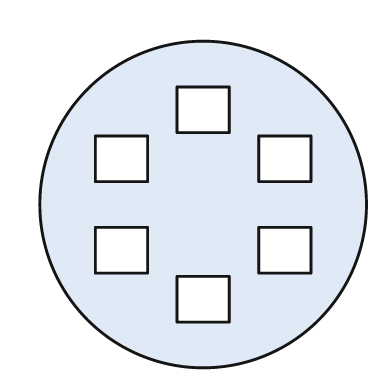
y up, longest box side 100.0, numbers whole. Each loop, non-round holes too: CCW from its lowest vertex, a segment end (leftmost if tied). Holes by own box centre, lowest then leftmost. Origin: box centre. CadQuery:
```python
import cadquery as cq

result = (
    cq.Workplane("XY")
    .moveTo(0.0, 0.0)
    .circle(50.0)
    .moveTo(-8.0, -36.0)
    .lineTo(8.0, -36.0)
    .lineTo(8.0, -22.0)
    .lineTo(-8.0, -22.0)
    .close()
    .moveTo(-33.0, -21.0)
    .lineTo(-17.0, -21.0)
    .lineTo(-17.0, -7.0)
    .lineTo(-33.0, -7.0)
    .close()
    .moveTo(17.0, -21.0)
    .lineTo(33.0, -21.0)
    .lineTo(33.0, -7.0)
    .lineTo(17.0, -7.0)
    .close()
    .moveTo(-33.0, 7.0)
    .lineTo(-17.0, 7.0)
    .lineTo(-17.0, 21.0)
    .lineTo(-33.0, 21.0)
    .close()
    .moveTo(17.0, 7.0)
    .lineTo(33.0, 7.0)
    .lineTo(33.0, 21.0)
    .lineTo(17.0, 21.0)
    .close()
    .moveTo(-8.0, 22.0)
    .lineTo(8.0, 22.0)
    .lineTo(8.0, 36.0)
    .lineTo(-8.0, 36.0)
    .close()
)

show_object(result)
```